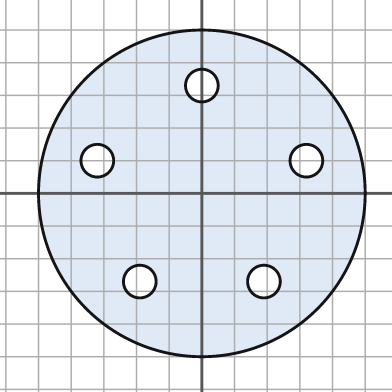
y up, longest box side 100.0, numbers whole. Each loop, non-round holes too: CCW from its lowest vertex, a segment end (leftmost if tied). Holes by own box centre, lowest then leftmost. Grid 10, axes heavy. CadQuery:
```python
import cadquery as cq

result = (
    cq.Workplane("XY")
    .moveTo(0.0, 0.0)
    .circle(50.0)
    .moveTo(-19.0, -27.0)
    .circle(5.0)
    .moveTo(19.0, -27.0)
    .circle(5.0)
    .moveTo(-32.0, 10.0)
    .circle(5.0)
    .moveTo(32.0, 10.0)
    .circle(5.0)
    .moveTo(0.0, 33.0)
    .circle(5.0)
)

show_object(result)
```